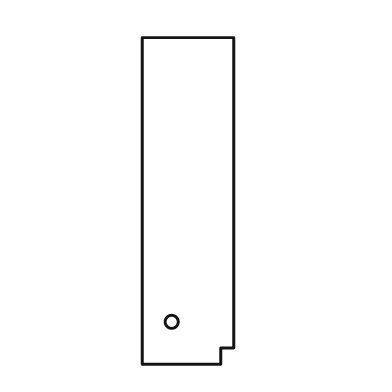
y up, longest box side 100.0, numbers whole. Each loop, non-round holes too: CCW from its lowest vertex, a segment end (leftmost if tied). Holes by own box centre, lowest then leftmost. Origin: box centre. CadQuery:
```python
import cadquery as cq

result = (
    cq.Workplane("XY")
    .moveTo(-14.0, -50.0)
    .lineTo(10.0, -50.0)
    .lineTo(10.0, -45.0)
    .lineTo(14.0, -45.0)
    .lineTo(14.0, 50.0)
    .lineTo(-14.0, 50.0)
    .close()
    .moveTo(-5.0, -37.0)
    .circle(2.0)
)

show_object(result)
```